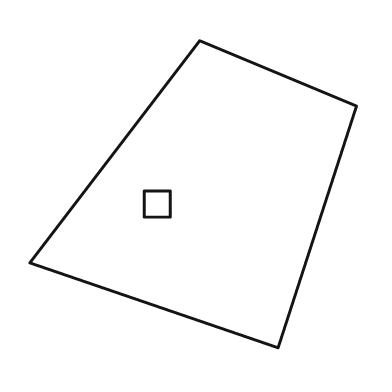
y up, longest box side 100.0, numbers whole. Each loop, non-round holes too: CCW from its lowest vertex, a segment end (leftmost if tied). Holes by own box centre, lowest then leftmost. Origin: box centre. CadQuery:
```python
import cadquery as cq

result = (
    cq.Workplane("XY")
    .moveTo(26.0, -47.0)
    .lineTo(50.0, 27.0)
    .lineTo(2.0, 47.0)
    .lineTo(-50.0, -21.0)
    .close()
    .moveTo(-15.0, -7.0)
    .lineTo(-7.0, -7.0)
    .lineTo(-7.0, 1.0)
    .lineTo(-15.0, 1.0)
    .close()
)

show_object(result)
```